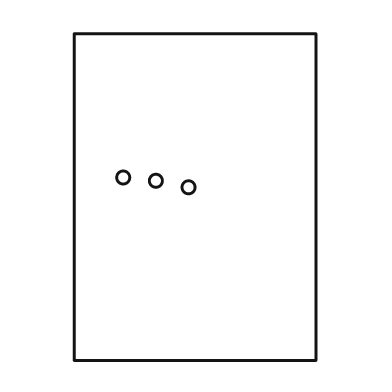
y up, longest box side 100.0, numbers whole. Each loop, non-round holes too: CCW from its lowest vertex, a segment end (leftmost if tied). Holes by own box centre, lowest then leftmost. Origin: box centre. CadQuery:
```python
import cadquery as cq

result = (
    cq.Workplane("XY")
    .moveTo(-37.0, -50.0)
    .lineTo(37.0, -50.0)
    .lineTo(37.0, 50.0)
    .lineTo(-37.0, 50.0)
    .close()
    .moveTo(-2.0, 3.0)
    .circle(2.0)
    .moveTo(-12.0, 5.0)
    .circle(2.0)
    .moveTo(-22.0, 6.0)
    .circle(2.0)
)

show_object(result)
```